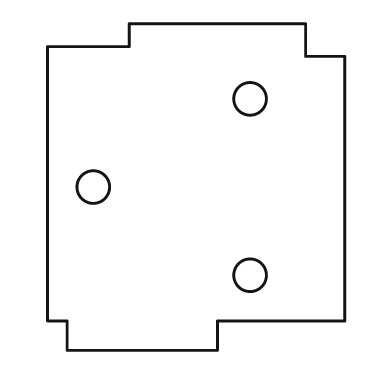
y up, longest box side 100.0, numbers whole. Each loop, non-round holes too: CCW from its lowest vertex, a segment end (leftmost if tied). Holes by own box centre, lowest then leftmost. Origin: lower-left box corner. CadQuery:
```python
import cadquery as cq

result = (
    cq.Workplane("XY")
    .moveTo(6.0, 0.0)
    .lineTo(52.0, 0.0)
    .lineTo(52.0, 9.0)
    .lineTo(91.0, 9.0)
    .lineTo(91.0, 90.0)
    .lineTo(79.0, 90.0)
    .lineTo(79.0, 100.0)
    .lineTo(25.0, 100.0)
    .lineTo(25.0, 93.0)
    .lineTo(0.0, 93.0)
    .lineTo(0.0, 9.0)
    .lineTo(6.0, 9.0)
    .close()
    .moveTo(62.0, 23.0)
    .circle(5.0)
    .moveTo(14.0, 50.0)
    .circle(5.0)
    .moveTo(62.0, 77.0)
    .circle(5.0)
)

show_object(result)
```